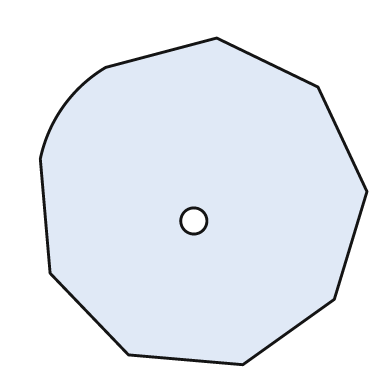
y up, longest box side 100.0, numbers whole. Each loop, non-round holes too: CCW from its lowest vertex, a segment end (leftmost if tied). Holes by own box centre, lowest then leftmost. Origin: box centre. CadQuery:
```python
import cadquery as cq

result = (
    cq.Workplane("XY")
    .moveTo(12.0, -50.0)
    .lineTo(40.0, -30.0)
    .lineTo(50.0, 3.0)
    .lineTo(35.0, 35.0)
    .lineTo(4.0, 50.0)
    .lineTo(-30.0, 41.0)
    .threePointArc((-43.0, 29.0), (-50.0, 13.0))
    .lineTo(-47.0, -22.0)
    .lineTo(-23.0, -47.0)
    .close()
    .moveTo(-3.0, -6.0)
    .circle(4.0)
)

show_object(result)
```